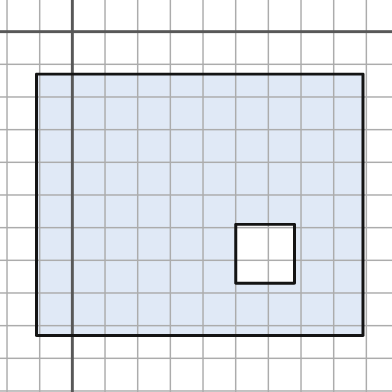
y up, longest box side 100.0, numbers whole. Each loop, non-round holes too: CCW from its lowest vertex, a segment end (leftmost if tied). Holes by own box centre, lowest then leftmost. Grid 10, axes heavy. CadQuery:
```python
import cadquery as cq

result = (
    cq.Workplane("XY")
    .moveTo(-11.0, -93.0)
    .lineTo(89.0, -93.0)
    .lineTo(89.0, -13.0)
    .lineTo(-11.0, -13.0)
    .close()
    .moveTo(50.0, -77.0)
    .lineTo(68.0, -77.0)
    .lineTo(68.0, -59.0)
    .lineTo(50.0, -59.0)
    .close()
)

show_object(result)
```